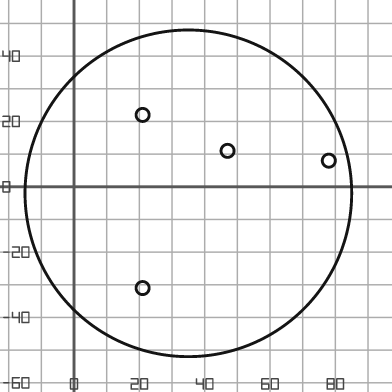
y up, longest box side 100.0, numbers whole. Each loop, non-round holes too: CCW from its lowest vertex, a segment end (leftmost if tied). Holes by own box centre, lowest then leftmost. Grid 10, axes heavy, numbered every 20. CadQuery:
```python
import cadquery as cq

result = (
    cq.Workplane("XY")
    .moveTo(35.0, -2.0)
    .circle(50.0)
    .moveTo(21.0, -31.0)
    .circle(2.0)
    .moveTo(78.0, 8.0)
    .circle(2.0)
    .moveTo(47.0, 11.0)
    .circle(2.0)
    .moveTo(21.0, 22.0)
    .circle(2.0)
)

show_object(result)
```